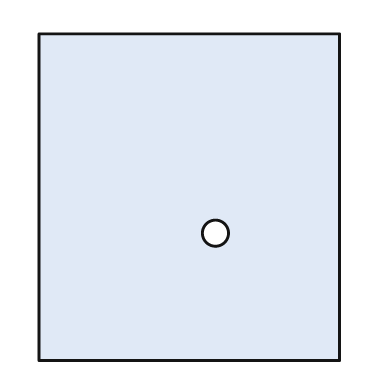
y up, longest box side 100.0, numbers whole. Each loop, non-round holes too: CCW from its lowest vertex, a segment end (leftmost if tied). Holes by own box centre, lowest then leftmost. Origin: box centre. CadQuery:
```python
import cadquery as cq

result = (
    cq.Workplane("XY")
    .moveTo(-46.0, -50.0)
    .lineTo(46.0, -50.0)
    .lineTo(46.0, 50.0)
    .lineTo(-46.0, 50.0)
    .close()
    .moveTo(8.0, -11.0)
    .circle(4.0)
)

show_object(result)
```